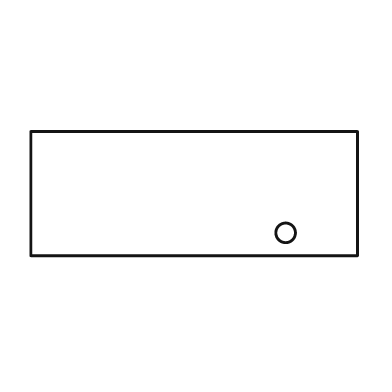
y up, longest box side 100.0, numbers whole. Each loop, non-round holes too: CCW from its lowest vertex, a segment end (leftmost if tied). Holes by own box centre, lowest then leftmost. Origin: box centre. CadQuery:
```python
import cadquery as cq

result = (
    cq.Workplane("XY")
    .moveTo(-50.0, -19.0)
    .lineTo(50.0, -19.0)
    .lineTo(50.0, 19.0)
    .lineTo(-50.0, 19.0)
    .close()
    .moveTo(28.0, -12.0)
    .circle(3.0)
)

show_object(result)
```